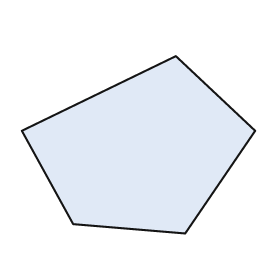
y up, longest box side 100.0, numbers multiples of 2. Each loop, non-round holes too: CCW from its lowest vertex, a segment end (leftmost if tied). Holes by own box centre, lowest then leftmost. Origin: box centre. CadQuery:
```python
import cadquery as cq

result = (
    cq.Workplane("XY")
    .moveTo(20.0, -38.0)
    .lineTo(50.0, 6.0)
    .lineTo(16.0, 38.0)
    .lineTo(-50.0, 6.0)
    .lineTo(-28.0, -34.0)
    .close()
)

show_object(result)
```